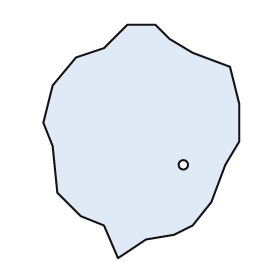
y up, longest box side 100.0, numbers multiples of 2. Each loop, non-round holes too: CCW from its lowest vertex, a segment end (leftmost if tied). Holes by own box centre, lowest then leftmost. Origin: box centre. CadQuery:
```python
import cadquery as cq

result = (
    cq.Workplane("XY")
    .moveTo(-10.0, -50.0)
    .lineTo(2.0, -42.0)
    .lineTo(14.0, -40.0)
    .lineTo(22.0, -36.0)
    .lineTo(30.0, -26.0)
    .lineTo(36.0, -10.0)
    .lineTo(42.0, 0.0)
    .lineTo(42.0, 16.0)
    .lineTo(38.0, 32.0)
    .lineTo(22.0, 38.0)
    .lineTo(12.0, 44.0)
    .lineTo(6.0, 50.0)
    .lineTo(-6.0, 50.0)
    .lineTo(-16.0, 40.0)
    .lineTo(-28.0, 36.0)
    .lineTo(-38.0, 24.0)
    .lineTo(-42.0, 8.0)
    .lineTo(-38.0, -2.0)
    .lineTo(-36.0, -22.0)
    .lineTo(-26.0, -32.0)
    .lineTo(-16.0, -36.0)
    .close()
    .moveTo(18.0, -10.0)
    .circle(2.0)
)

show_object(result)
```